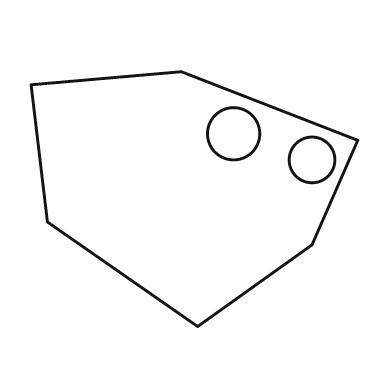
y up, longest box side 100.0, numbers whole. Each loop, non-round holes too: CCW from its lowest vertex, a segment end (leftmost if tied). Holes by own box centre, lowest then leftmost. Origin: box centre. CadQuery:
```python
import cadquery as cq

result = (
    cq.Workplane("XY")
    .moveTo(1.0, -39.0)
    .lineTo(36.0, -14.0)
    .lineTo(50.0, 18.0)
    .lineTo(-4.0, 39.0)
    .lineTo(-50.0, 35.0)
    .lineTo(-45.0, -7.0)
    .close()
    .moveTo(36.0, 12.0)
    .circle(7.0)
    .moveTo(12.0, 20.0)
    .circle(8.0)
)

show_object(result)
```